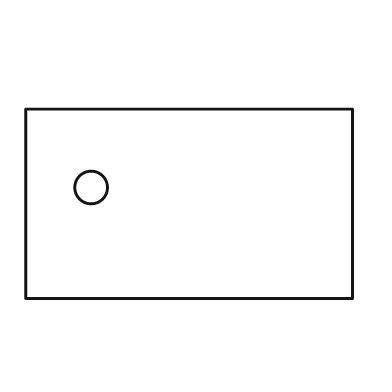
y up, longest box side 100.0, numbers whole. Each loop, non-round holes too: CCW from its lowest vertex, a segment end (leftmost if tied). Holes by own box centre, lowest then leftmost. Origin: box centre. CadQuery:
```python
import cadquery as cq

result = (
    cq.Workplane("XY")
    .moveTo(-50.0, -29.0)
    .lineTo(50.0, -29.0)
    .lineTo(50.0, 29.0)
    .lineTo(-50.0, 29.0)
    .close()
    .moveTo(-30.0, 5.0)
    .circle(5.0)
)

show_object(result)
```